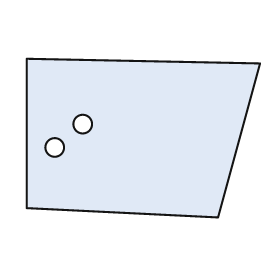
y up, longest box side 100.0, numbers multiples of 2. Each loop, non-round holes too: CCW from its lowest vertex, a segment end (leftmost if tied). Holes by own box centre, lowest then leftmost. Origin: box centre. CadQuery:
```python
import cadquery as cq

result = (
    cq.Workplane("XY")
    .moveTo(32.0, -34.0)
    .lineTo(50.0, 32.0)
    .lineTo(-50.0, 34.0)
    .lineTo(-50.0, -30.0)
    .close()
    .moveTo(-38.0, -4.0)
    .circle(4.0)
    .moveTo(-26.0, 6.0)
    .circle(4.0)
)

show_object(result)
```